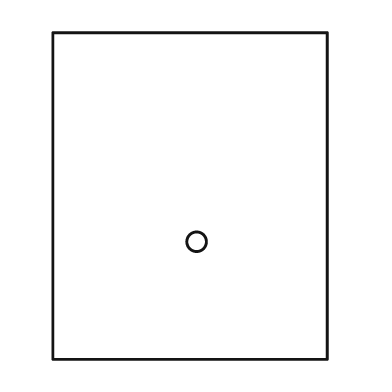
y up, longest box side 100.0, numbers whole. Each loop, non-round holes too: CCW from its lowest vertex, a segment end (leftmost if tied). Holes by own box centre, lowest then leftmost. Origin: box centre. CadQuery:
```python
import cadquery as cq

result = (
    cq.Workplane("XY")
    .moveTo(-42.0, -50.0)
    .lineTo(42.0, -50.0)
    .lineTo(42.0, 50.0)
    .lineTo(-42.0, 50.0)
    .close()
    .moveTo(2.0, -14.0)
    .circle(3.0)
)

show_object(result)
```